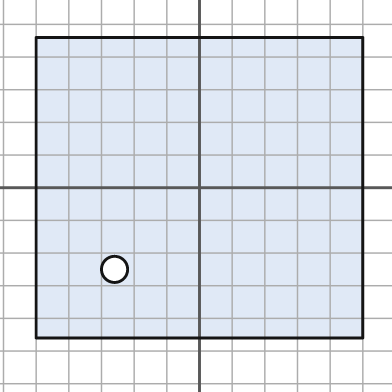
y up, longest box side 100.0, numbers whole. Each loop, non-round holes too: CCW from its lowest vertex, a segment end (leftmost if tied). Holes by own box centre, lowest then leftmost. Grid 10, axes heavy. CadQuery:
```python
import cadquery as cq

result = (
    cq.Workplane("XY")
    .moveTo(-50.0, -46.0)
    .lineTo(50.0, -46.0)
    .lineTo(50.0, 46.0)
    .lineTo(-50.0, 46.0)
    .close()
    .moveTo(-26.0, -25.0)
    .circle(4.0)
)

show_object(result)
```